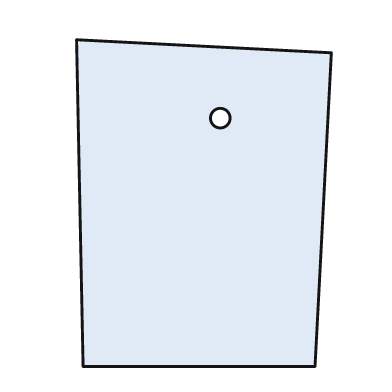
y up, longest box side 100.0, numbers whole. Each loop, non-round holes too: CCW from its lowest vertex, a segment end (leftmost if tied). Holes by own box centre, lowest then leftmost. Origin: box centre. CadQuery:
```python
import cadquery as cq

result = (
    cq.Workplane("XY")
    .moveTo(-37.0, -50.0)
    .lineTo(34.0, -50.0)
    .lineTo(39.0, 46.0)
    .lineTo(-39.0, 50.0)
    .close()
    .moveTo(5.0, 26.0)
    .circle(3.0)
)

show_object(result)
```